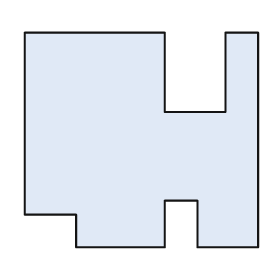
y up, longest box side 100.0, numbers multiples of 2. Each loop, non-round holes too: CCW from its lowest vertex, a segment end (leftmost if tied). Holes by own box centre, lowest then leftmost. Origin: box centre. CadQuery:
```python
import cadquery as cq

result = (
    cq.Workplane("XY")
    .moveTo(-28.0, -46.0)
    .lineTo(10.0, -46.0)
    .lineTo(10.0, -26.0)
    .lineTo(24.0, -26.0)
    .lineTo(24.0, -46.0)
    .lineTo(50.0, -46.0)
    .lineTo(50.0, 46.0)
    .lineTo(36.0, 46.0)
    .lineTo(36.0, 12.0)
    .lineTo(10.0, 12.0)
    .lineTo(10.0, 46.0)
    .lineTo(-50.0, 46.0)
    .lineTo(-50.0, -32.0)
    .lineTo(-28.0, -32.0)
    .close()
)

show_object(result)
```